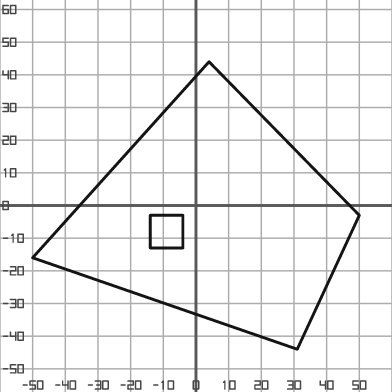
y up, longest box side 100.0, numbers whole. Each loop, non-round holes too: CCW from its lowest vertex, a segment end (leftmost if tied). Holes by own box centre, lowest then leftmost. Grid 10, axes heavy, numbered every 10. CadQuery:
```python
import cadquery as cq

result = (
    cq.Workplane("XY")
    .moveTo(31.0, -44.0)
    .lineTo(50.0, -3.0)
    .lineTo(4.0, 44.0)
    .lineTo(-50.0, -16.0)
    .close()
    .moveTo(-14.0, -13.0)
    .lineTo(-4.0, -13.0)
    .lineTo(-4.0, -3.0)
    .lineTo(-14.0, -3.0)
    .close()
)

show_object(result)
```